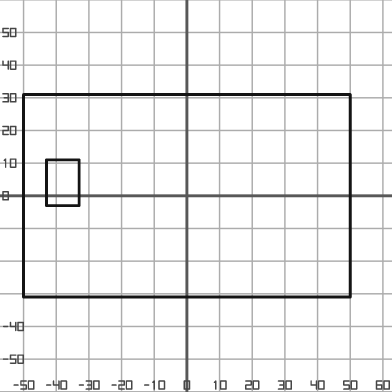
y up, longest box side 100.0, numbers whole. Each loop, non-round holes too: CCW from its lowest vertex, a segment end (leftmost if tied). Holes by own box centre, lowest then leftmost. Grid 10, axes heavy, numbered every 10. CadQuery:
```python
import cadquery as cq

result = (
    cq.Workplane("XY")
    .moveTo(-50.0, -31.0)
    .lineTo(50.0, -31.0)
    .lineTo(50.0, 31.0)
    .lineTo(-50.0, 31.0)
    .close()
    .moveTo(-43.0, -3.0)
    .lineTo(-33.0, -3.0)
    .lineTo(-33.0, 11.0)
    .lineTo(-43.0, 11.0)
    .close()
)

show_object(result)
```